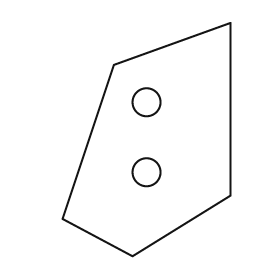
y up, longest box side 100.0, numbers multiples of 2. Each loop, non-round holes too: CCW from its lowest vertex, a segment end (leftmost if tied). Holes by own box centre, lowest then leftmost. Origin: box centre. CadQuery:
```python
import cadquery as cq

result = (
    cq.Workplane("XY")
    .moveTo(-6.0, -50.0)
    .lineTo(36.0, -24.0)
    .lineTo(36.0, 50.0)
    .lineTo(-14.0, 32.0)
    .lineTo(-36.0, -34.0)
    .close()
    .moveTo(0.0, -14.0)
    .circle(6.0)
    .moveTo(0.0, 16.0)
    .circle(6.0)
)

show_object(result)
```